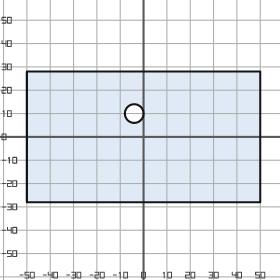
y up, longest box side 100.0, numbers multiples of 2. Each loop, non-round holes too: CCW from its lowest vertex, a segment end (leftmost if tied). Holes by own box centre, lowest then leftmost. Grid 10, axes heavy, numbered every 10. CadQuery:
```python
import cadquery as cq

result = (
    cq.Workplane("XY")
    .moveTo(-50.0, -28.0)
    .lineTo(50.0, -28.0)
    .lineTo(50.0, 28.0)
    .lineTo(-50.0, 28.0)
    .close()
    .moveTo(-4.0, 10.0)
    .circle(4.0)
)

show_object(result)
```